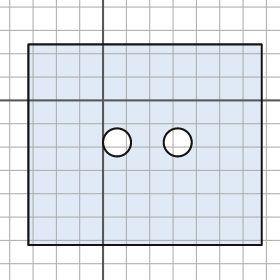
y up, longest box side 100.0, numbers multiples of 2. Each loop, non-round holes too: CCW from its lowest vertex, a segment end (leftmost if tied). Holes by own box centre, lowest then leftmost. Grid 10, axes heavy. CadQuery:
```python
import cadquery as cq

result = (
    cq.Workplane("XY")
    .moveTo(-32.0, -62.0)
    .lineTo(68.0, -62.0)
    .lineTo(68.0, 24.0)
    .lineTo(-32.0, 24.0)
    .close()
    .moveTo(6.0, -18.0)
    .circle(6.0)
    .moveTo(32.0, -18.0)
    .circle(6.0)
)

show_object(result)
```